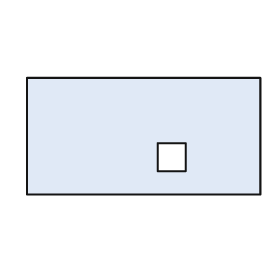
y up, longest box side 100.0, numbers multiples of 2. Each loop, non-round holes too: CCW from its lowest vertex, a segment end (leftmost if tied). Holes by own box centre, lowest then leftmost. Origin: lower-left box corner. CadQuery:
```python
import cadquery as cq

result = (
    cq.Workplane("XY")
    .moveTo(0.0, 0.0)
    .lineTo(100.0, 0.0)
    .lineTo(100.0, 50.0)
    .lineTo(0.0, 50.0)
    .close()
    .moveTo(56.0, 10.0)
    .lineTo(68.0, 10.0)
    .lineTo(68.0, 22.0)
    .lineTo(56.0, 22.0)
    .close()
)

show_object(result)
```